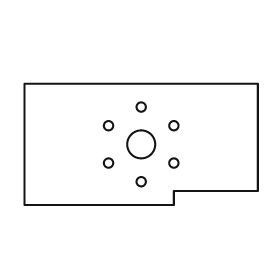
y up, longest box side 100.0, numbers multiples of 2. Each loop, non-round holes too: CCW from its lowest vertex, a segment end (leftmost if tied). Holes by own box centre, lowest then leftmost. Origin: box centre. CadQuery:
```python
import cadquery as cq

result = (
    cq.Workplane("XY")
    .moveTo(-50.0, -26.0)
    .lineTo(14.0, -26.0)
    .lineTo(14.0, -20.0)
    .lineTo(50.0, -20.0)
    .lineTo(50.0, 26.0)
    .lineTo(-50.0, 26.0)
    .close()
    .moveTo(0.0, -16.0)
    .circle(2.0)
    .moveTo(-14.0, -8.0)
    .circle(2.0)
    .moveTo(14.0, -8.0)
    .circle(2.0)
    .moveTo(0.0, 0.0)
    .circle(6.0)
    .moveTo(-14.0, 8.0)
    .circle(2.0)
    .moveTo(14.0, 8.0)
    .circle(2.0)
    .moveTo(0.0, 16.0)
    .circle(2.0)
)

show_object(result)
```